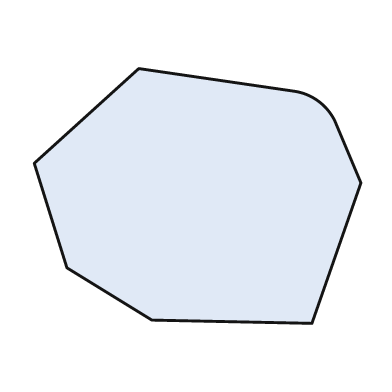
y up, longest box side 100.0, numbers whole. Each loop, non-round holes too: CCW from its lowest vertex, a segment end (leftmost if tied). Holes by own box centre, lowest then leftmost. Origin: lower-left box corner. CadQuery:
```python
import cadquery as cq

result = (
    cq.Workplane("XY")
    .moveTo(85.0, 0.0)
    .lineTo(100.0, 43.0)
    .lineTo(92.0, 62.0)
    .threePointArc((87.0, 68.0), (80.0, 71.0))
    .lineTo(32.0, 78.0)
    .lineTo(0.0, 49.0)
    .lineTo(10.0, 17.0)
    .lineTo(36.0, 1.0)
    .close()
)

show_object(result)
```